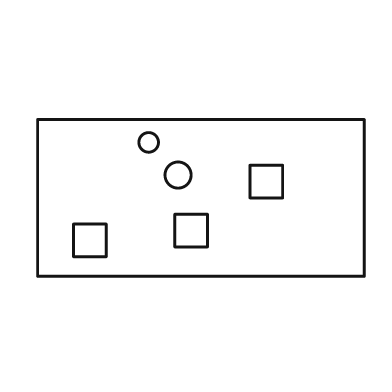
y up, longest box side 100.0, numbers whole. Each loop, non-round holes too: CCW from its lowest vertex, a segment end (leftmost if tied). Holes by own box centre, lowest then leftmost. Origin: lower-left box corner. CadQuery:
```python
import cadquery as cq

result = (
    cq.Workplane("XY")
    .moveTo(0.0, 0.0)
    .lineTo(100.0, 0.0)
    .lineTo(100.0, 48.0)
    .lineTo(0.0, 48.0)
    .close()
    .moveTo(11.0, 6.0)
    .lineTo(21.0, 6.0)
    .lineTo(21.0, 16.0)
    .lineTo(11.0, 16.0)
    .close()
    .moveTo(42.0, 9.0)
    .lineTo(52.0, 9.0)
    .lineTo(52.0, 19.0)
    .lineTo(42.0, 19.0)
    .close()
    .moveTo(65.0, 24.0)
    .lineTo(75.0, 24.0)
    .lineTo(75.0, 34.0)
    .lineTo(65.0, 34.0)
    .close()
    .moveTo(43.0, 31.0)
    .circle(4.0)
    .moveTo(34.0, 41.0)
    .circle(3.0)
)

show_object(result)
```